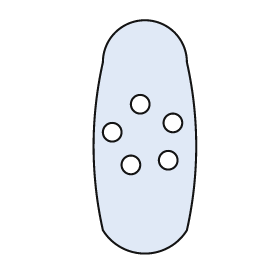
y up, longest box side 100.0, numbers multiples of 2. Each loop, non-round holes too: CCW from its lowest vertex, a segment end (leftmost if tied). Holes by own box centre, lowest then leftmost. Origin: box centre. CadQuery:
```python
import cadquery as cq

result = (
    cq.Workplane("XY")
    .moveTo(-18.0, -40.0)
    .threePointArc((0.0, -50.0), (18.0, -40.0))
    .threePointArc((22.0, -4.0), (18.0, 32.0))
    .threePointArc((0.0, 50.0), (-18.0, 32.0))
    .threePointArc((-22.0, -4.0), (-18.0, -40.0))
    .close()
    .moveTo(-6.0, -12.0)
    .circle(4.0)
    .moveTo(10.0, -10.0)
    .circle(4.0)
    .moveTo(-14.0, 2.0)
    .circle(4.0)
    .moveTo(12.0, 6.0)
    .circle(4.0)
    .moveTo(-2.0, 14.0)
    .circle(4.0)
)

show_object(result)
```